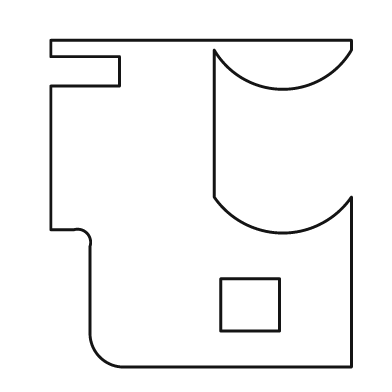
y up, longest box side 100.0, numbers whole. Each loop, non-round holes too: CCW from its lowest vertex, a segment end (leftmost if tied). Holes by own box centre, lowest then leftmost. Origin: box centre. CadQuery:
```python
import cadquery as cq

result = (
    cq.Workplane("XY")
    .moveTo(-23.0, -50.0)
    .lineTo(46.0, -50.0)
    .lineTo(46.0, 2.0)
    .threePointArc((25.0, -9.0), (4.0, 2.0))
    .lineTo(4.0, 47.0)
    .threePointArc((25.0, 35.0), (46.0, 47.0))
    .lineTo(46.0, 50.0)
    .lineTo(-46.0, 50.0)
    .lineTo(-46.0, 45.0)
    .lineTo(-25.0, 45.0)
    .lineTo(-25.0, 36.0)
    .lineTo(-46.0, 36.0)
    .lineTo(-46.0, -8.0)
    .lineTo(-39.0, -8.0)
    .threePointArc((-35.0, -9.0), (-34.0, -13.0))
    .lineTo(-34.0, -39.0)
    .threePointArc((-31.0, -47.0), (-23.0, -50.0))
    .close()
    .moveTo(6.0, -39.0)
    .lineTo(24.0, -39.0)
    .lineTo(24.0, -23.0)
    .lineTo(6.0, -23.0)
    .close()
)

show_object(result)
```